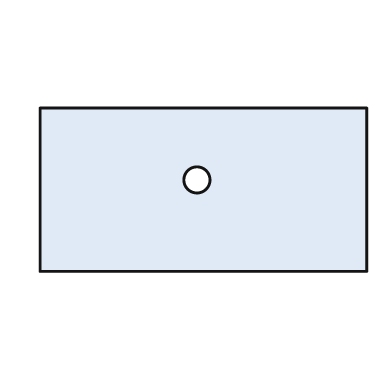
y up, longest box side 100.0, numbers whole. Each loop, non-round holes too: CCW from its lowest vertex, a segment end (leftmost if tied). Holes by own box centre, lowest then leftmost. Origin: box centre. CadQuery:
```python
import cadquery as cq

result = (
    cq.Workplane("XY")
    .moveTo(-50.0, -25.0)
    .lineTo(50.0, -25.0)
    .lineTo(50.0, 25.0)
    .lineTo(-50.0, 25.0)
    .close()
    .moveTo(-2.0, 3.0)
    .circle(4.0)
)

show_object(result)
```